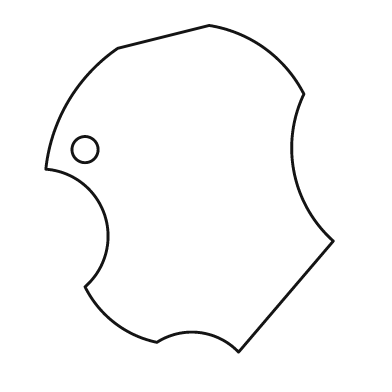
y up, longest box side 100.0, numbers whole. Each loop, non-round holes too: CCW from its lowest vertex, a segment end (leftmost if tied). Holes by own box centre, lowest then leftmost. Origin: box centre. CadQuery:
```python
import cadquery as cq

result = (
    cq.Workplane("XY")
    .moveTo(15.0, -50.0)
    .lineTo(44.0, -16.0)
    .threePointArc((32.0, 5.0), (35.0, 29.0))
    .threePointArc((23.0, 43.0), (6.0, 50.0))
    .lineTo(-22.0, 43.0)
    .threePointArc((-37.0, 27.0), (-44.0, 6.0))
    .threePointArc((-26.0, -8.0), (-32.0, -30.0))
    .threePointArc((-23.0, -41.0), (-10.0, -47.0))
    .threePointArc((3.0, -44.0), (15.0, -50.0))
    .close()
    .moveTo(-32.0, 12.0)
    .circle(4.0)
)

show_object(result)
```